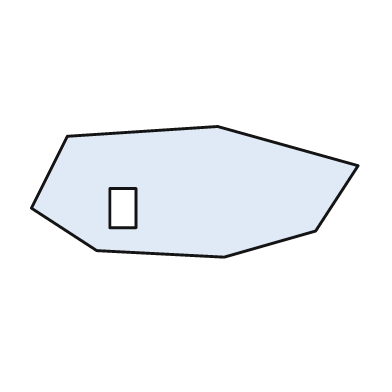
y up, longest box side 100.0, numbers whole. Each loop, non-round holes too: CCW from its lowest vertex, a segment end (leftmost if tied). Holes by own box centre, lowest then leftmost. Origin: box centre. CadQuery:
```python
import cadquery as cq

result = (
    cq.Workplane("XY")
    .moveTo(9.0, -20.0)
    .lineTo(37.0, -12.0)
    .lineTo(50.0, 8.0)
    .lineTo(7.0, 20.0)
    .lineTo(-39.0, 17.0)
    .lineTo(-50.0, -5.0)
    .lineTo(-30.0, -18.0)
    .close()
    .moveTo(-26.0, -11.0)
    .lineTo(-18.0, -11.0)
    .lineTo(-18.0, 1.0)
    .lineTo(-26.0, 1.0)
    .close()
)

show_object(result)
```